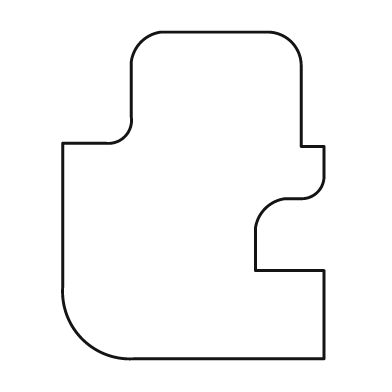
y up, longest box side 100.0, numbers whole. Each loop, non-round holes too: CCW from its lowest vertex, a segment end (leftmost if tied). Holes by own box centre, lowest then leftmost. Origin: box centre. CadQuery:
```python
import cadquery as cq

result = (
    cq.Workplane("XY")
    .moveTo(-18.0, -50.0)
    .lineTo(40.0, -50.0)
    .lineTo(40.0, -23.0)
    .lineTo(19.0, -23.0)
    .lineTo(19.0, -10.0)
    .threePointArc((22.0, -4.0), (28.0, -1.0))
    .lineTo(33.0, -1.0)
    .threePointArc((38.0, 1.0), (40.0, 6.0))
    .lineTo(40.0, 15.0)
    .lineTo(33.0, 15.0)
    .lineTo(33.0, 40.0)
    .threePointArc((30.0, 47.0), (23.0, 50.0))
    .lineTo(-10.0, 50.0)
    .threePointArc((-16.0, 47.0), (-19.0, 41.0))
    .lineTo(-19.0, 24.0)
    .threePointArc((-21.0, 18.0), (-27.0, 16.0))
    .lineTo(-40.0, 16.0)
    .lineTo(-40.0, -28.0)
    .threePointArc((-34.0, -44.0), (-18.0, -50.0))
    .close()
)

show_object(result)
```